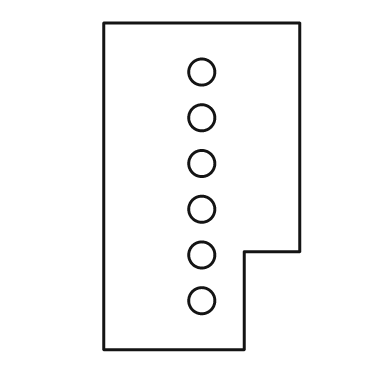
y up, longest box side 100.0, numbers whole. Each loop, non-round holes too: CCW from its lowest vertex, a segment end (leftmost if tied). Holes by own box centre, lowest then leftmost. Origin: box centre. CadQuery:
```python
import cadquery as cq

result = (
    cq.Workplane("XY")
    .moveTo(-30.0, -50.0)
    .lineTo(13.0, -50.0)
    .lineTo(13.0, -20.0)
    .lineTo(30.0, -20.0)
    .lineTo(30.0, 50.0)
    .lineTo(-30.0, 50.0)
    .close()
    .moveTo(0.0, -35.0)
    .circle(4.0)
    .moveTo(0.0, -21.0)
    .circle(4.0)
    .moveTo(0.0, -7.0)
    .circle(4.0)
    .moveTo(0.0, 7.0)
    .circle(4.0)
    .moveTo(0.0, 21.0)
    .circle(4.0)
    .moveTo(0.0, 35.0)
    .circle(4.0)
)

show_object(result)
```